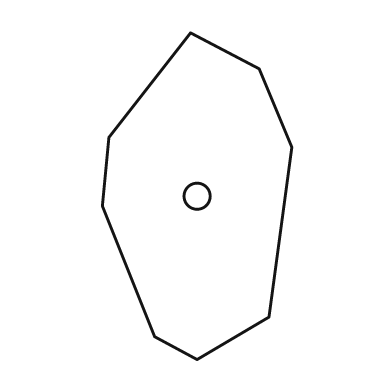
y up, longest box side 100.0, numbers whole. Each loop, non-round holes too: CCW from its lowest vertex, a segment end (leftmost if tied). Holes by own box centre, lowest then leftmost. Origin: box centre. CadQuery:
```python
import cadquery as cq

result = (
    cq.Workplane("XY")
    .moveTo(0.0, -50.0)
    .lineTo(22.0, -37.0)
    .lineTo(29.0, 15.0)
    .lineTo(19.0, 39.0)
    .lineTo(-2.0, 50.0)
    .lineTo(-27.0, 18.0)
    .lineTo(-29.0, -3.0)
    .lineTo(-13.0, -43.0)
    .close()
    .moveTo(0.0, 0.0)
    .circle(4.0)
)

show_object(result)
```